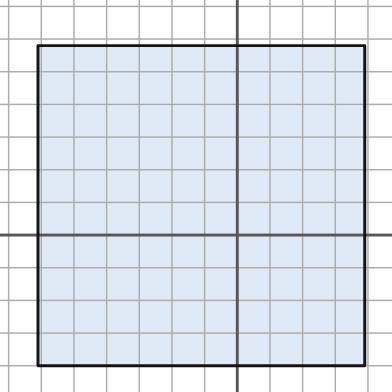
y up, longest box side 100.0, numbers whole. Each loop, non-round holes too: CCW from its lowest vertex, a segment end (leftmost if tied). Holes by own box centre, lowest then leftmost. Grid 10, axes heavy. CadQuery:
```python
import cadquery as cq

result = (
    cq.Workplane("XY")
    .moveTo(-61.0, -40.0)
    .lineTo(39.0, -40.0)
    .lineTo(39.0, 58.0)
    .lineTo(-61.0, 58.0)
    .close()
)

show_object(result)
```